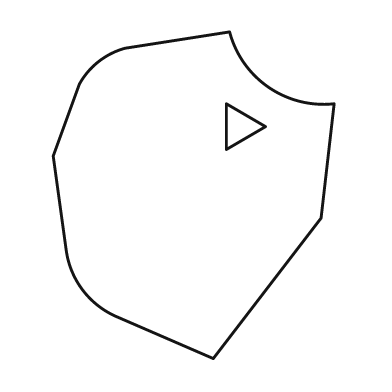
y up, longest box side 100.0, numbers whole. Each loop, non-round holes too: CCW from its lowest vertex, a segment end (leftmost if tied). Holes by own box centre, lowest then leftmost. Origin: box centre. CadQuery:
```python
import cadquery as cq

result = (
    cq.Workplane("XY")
    .moveTo(6.0, -50.0)
    .lineTo(39.0, -7.0)
    .lineTo(43.0, 28.0)
    .threePointArc((23.0, 33.0), (11.0, 50.0))
    .lineTo(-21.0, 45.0)
    .threePointArc((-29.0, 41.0), (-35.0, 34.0))
    .lineTo(-43.0, 12.0)
    .lineTo(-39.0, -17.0)
    .threePointArc((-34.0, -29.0), (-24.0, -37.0))
    .close()
    .moveTo(10.0, 14.0)
    .lineTo(22.0, 21.0)
    .lineTo(10.0, 28.0)
    .close()
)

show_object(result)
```